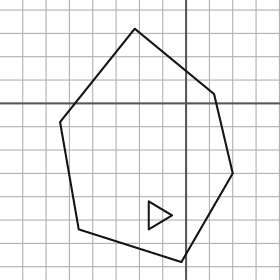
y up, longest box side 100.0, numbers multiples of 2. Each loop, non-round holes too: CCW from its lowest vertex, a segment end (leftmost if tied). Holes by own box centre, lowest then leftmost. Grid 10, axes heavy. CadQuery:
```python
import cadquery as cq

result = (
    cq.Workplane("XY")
    .moveTo(-2.0, -68.0)
    .lineTo(20.0, -30.0)
    .lineTo(12.0, 4.0)
    .lineTo(-22.0, 32.0)
    .lineTo(-54.0, -8.0)
    .lineTo(-46.0, -54.0)
    .close()
    .moveTo(-16.0, -54.0)
    .lineTo(-6.0, -48.0)
    .lineTo(-16.0, -42.0)
    .close()
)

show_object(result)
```